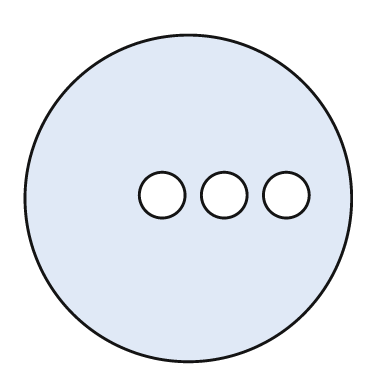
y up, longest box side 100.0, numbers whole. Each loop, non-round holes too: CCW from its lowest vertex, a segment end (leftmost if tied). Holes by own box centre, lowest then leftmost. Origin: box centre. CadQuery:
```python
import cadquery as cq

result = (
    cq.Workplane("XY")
    .moveTo(0.0, 0.0)
    .circle(50.0)
    .moveTo(-8.0, 1.0)
    .circle(7.0)
    .moveTo(11.0, 1.0)
    .circle(7.0)
    .moveTo(30.0, 1.0)
    .circle(7.0)
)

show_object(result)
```